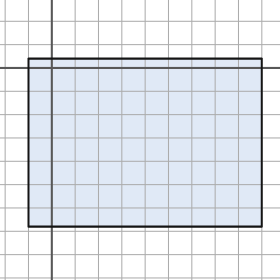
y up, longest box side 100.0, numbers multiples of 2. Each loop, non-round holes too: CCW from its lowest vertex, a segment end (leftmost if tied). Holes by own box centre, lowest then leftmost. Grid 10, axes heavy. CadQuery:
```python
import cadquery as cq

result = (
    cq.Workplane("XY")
    .moveTo(-10.0, -68.0)
    .lineTo(90.0, -68.0)
    .lineTo(90.0, 4.0)
    .lineTo(-10.0, 4.0)
    .close()
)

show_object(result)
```